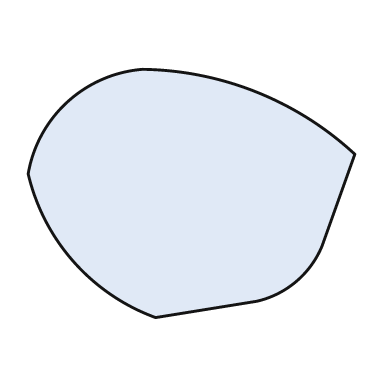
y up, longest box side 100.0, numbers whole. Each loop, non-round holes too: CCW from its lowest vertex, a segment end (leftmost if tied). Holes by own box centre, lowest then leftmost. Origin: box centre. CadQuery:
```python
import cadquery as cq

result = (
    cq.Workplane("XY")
    .moveTo(-11.0, -38.0)
    .lineTo(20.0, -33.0)
    .threePointArc((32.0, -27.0), (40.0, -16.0))
    .lineTo(50.0, 12.0)
    .threePointArc((20.0, 31.0), (-15.0, 38.0))
    .threePointArc((-38.0, 28.0), (-50.0, 6.0))
    .threePointArc((-36.0, -21.0), (-11.0, -38.0))
    .close()
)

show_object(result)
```